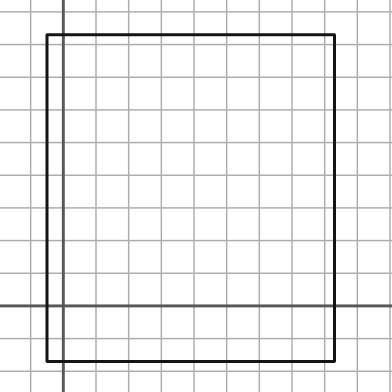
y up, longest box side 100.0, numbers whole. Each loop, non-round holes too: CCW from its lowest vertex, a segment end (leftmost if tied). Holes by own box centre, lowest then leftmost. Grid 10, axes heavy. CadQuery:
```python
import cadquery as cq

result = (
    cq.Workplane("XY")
    .moveTo(-5.0, -17.0)
    .lineTo(83.0, -17.0)
    .lineTo(83.0, 83.0)
    .lineTo(-5.0, 83.0)
    .close()
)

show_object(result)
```